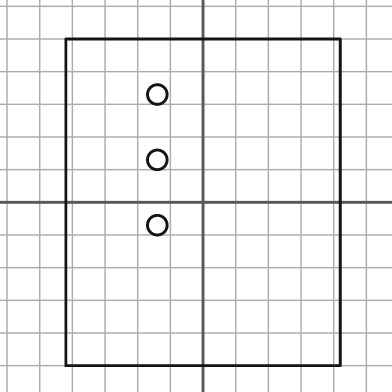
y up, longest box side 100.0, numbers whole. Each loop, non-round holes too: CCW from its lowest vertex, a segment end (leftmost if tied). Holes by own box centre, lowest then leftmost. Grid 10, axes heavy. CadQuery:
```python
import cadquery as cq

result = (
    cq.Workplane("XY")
    .moveTo(-42.0, -50.0)
    .lineTo(42.0, -50.0)
    .lineTo(42.0, 50.0)
    .lineTo(-42.0, 50.0)
    .close()
    .moveTo(-14.0, -7.0)
    .circle(3.0)
    .moveTo(-14.0, 13.0)
    .circle(3.0)
    .moveTo(-14.0, 33.0)
    .circle(3.0)
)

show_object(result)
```